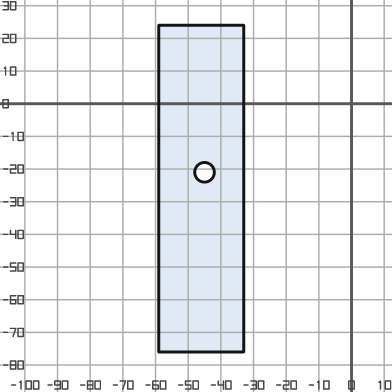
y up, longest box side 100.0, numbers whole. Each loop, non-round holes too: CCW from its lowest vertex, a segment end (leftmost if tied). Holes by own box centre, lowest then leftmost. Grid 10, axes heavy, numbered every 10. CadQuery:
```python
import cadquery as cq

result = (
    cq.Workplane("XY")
    .moveTo(-59.0, -76.0)
    .lineTo(-33.0, -76.0)
    .lineTo(-33.0, 24.0)
    .lineTo(-59.0, 24.0)
    .close()
    .moveTo(-45.0, -21.0)
    .circle(3.0)
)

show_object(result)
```